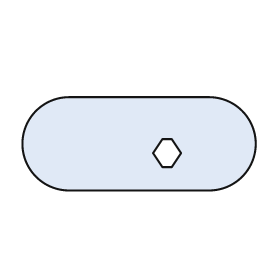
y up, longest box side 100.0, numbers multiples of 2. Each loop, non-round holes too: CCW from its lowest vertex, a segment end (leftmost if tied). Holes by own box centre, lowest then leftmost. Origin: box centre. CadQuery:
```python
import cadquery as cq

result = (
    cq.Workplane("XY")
    .moveTo(-30.0, -20.0)
    .lineTo(30.0, -20.0)
    .threePointArc((50.0, 0.0), (30.0, 20.0))
    .lineTo(-30.0, 20.0)
    .threePointArc((-50.0, 0.0), (-30.0, -20.0))
    .close()
    .moveTo(10.0, -10.0)
    .lineTo(14.0, -10.0)
    .lineTo(18.0, -4.0)
    .lineTo(14.0, 2.0)
    .lineTo(10.0, 2.0)
    .lineTo(6.0, -4.0)
    .close()
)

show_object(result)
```